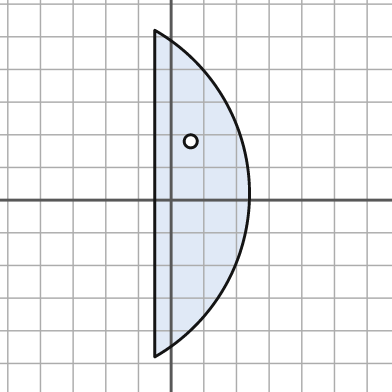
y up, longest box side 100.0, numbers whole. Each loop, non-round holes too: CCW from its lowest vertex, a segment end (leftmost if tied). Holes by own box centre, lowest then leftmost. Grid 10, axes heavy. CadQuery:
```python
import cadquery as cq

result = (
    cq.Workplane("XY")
    .moveTo(-5.0, -48.0)
    .threePointArc((24.0, 2.0), (-5.0, 52.0))
    .close()
    .moveTo(6.0, 18.0)
    .circle(2.0)
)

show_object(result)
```